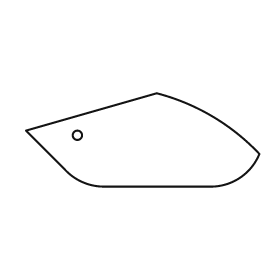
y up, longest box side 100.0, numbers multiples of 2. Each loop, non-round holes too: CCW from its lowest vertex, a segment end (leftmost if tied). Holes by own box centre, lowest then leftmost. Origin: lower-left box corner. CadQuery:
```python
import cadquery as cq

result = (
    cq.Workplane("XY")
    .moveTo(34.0, 0.0)
    .lineTo(80.0, 0.0)
    .threePointArc((92.0, 4.0), (100.0, 14.0))
    .threePointArc((80.0, 30.0), (56.0, 40.0))
    .lineTo(0.0, 24.0)
    .lineTo(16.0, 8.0)
    .threePointArc((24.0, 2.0), (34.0, 0.0))
    .close()
    .moveTo(22.0, 22.0)
    .circle(2.0)
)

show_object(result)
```